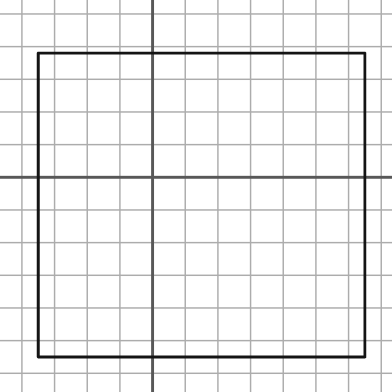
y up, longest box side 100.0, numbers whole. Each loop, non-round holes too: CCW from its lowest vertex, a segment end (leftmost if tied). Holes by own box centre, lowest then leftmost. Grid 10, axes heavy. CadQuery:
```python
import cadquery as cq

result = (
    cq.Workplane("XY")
    .moveTo(-35.0, -55.0)
    .lineTo(65.0, -55.0)
    .lineTo(65.0, 38.0)
    .lineTo(-35.0, 38.0)
    .close()
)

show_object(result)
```